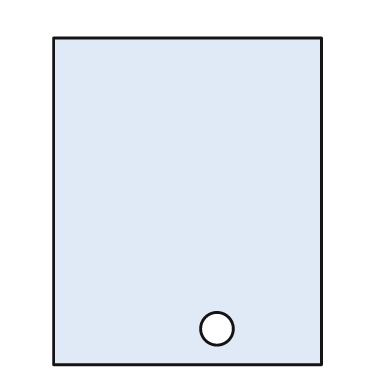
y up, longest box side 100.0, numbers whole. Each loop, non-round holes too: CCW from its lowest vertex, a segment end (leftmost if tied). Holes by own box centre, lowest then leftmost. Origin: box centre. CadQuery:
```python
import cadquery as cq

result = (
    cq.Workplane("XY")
    .moveTo(-41.0, -50.0)
    .lineTo(41.0, -50.0)
    .lineTo(41.0, 50.0)
    .lineTo(-41.0, 50.0)
    .close()
    .moveTo(9.0, -39.0)
    .circle(5.0)
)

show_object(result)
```